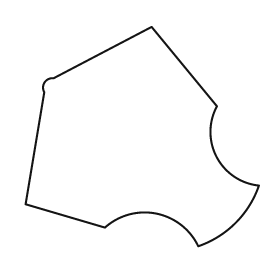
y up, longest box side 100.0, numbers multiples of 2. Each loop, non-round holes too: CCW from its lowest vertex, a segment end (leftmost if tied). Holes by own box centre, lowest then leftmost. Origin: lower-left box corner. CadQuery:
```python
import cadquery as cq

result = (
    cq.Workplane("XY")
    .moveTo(74.0, 0.0)
    .threePointArc((90.0, 10.0), (100.0, 26.0))
    .threePointArc((82.0, 38.0), (82.0, 60.0))
    .lineTo(54.0, 94.0)
    .lineTo(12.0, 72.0)
    .threePointArc((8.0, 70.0), (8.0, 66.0))
    .lineTo(0.0, 18.0)
    .lineTo(34.0, 8.0)
    .threePointArc((56.0, 14.0), (74.0, 0.0))
    .close()
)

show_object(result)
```